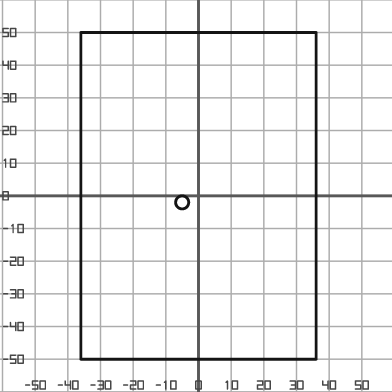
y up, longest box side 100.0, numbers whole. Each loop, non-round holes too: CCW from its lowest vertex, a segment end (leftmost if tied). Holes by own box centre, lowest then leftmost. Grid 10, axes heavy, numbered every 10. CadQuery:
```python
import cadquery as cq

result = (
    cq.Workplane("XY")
    .moveTo(-36.0, -50.0)
    .lineTo(36.0, -50.0)
    .lineTo(36.0, 50.0)
    .lineTo(-36.0, 50.0)
    .close()
    .moveTo(-5.0, -2.0)
    .circle(2.0)
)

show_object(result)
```